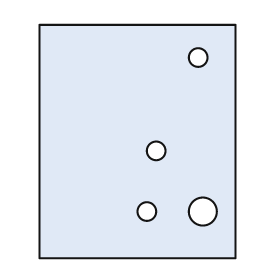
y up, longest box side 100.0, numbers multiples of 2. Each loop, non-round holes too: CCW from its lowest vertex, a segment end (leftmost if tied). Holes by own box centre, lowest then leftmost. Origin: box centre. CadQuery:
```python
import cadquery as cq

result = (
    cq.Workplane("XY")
    .moveTo(-42.0, -50.0)
    .lineTo(42.0, -50.0)
    .lineTo(42.0, 50.0)
    .lineTo(-42.0, 50.0)
    .close()
    .moveTo(4.0, -30.0)
    .circle(4.0)
    .moveTo(28.0, -30.0)
    .circle(6.0)
    .moveTo(8.0, -4.0)
    .circle(4.0)
    .moveTo(26.0, 36.0)
    .circle(4.0)
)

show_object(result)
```